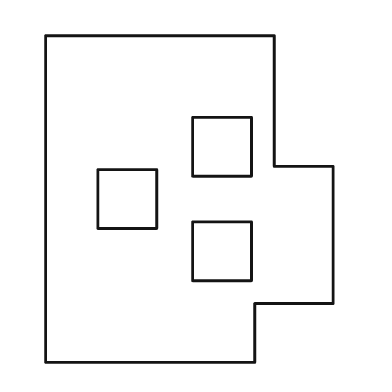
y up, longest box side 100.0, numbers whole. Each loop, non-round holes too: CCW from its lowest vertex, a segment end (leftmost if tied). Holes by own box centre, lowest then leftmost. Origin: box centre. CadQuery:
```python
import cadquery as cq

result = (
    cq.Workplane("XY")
    .moveTo(-44.0, -50.0)
    .lineTo(20.0, -50.0)
    .lineTo(20.0, -32.0)
    .lineTo(44.0, -32.0)
    .lineTo(44.0, 10.0)
    .lineTo(26.0, 10.0)
    .lineTo(26.0, 50.0)
    .lineTo(-44.0, 50.0)
    .close()
    .moveTo(1.0, -25.0)
    .lineTo(19.0, -25.0)
    .lineTo(19.0, -7.0)
    .lineTo(1.0, -7.0)
    .close()
    .moveTo(-28.0, -9.0)
    .lineTo(-10.0, -9.0)
    .lineTo(-10.0, 9.0)
    .lineTo(-28.0, 9.0)
    .close()
    .moveTo(1.0, 7.0)
    .lineTo(19.0, 7.0)
    .lineTo(19.0, 25.0)
    .lineTo(1.0, 25.0)
    .close()
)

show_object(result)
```